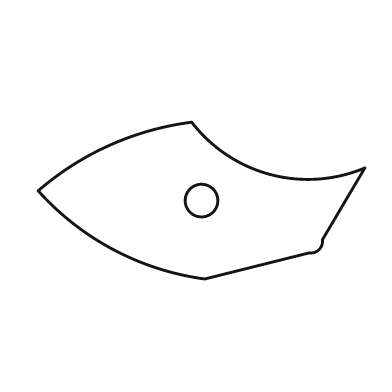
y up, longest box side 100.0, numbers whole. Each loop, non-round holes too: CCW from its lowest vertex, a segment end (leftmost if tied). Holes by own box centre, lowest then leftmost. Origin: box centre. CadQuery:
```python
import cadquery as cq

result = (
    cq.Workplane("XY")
    .moveTo(1.0, -24.0)
    .lineTo(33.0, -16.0)
    .threePointArc((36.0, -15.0), (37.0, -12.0))
    .lineTo(50.0, 10.0)
    .threePointArc((21.0, 8.0), (-3.0, 24.0))
    .threePointArc((-28.0, 17.0), (-50.0, 3.0))
    .threePointArc((-27.0, -15.0), (1.0, -24.0))
    .close()
    .moveTo(0.0, 0.0)
    .circle(5.0)
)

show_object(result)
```